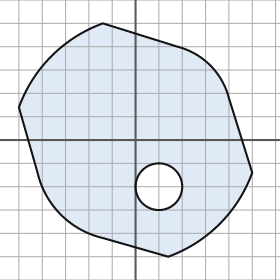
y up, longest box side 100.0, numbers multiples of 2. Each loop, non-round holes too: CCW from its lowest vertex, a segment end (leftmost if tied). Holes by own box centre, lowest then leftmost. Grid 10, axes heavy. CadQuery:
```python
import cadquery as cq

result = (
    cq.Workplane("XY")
    .moveTo(14.0, -50.0)
    .threePointArc((36.0, -36.0), (50.0, -14.0))
    .lineTo(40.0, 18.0)
    .threePointArc((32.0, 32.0), (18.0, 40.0))
    .lineTo(-14.0, 50.0)
    .threePointArc((-36.0, 36.0), (-50.0, 14.0))
    .lineTo(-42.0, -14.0)
    .threePointArc((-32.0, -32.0), (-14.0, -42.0))
    .close()
    .moveTo(10.0, -20.0)
    .circle(10.0)
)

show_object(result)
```